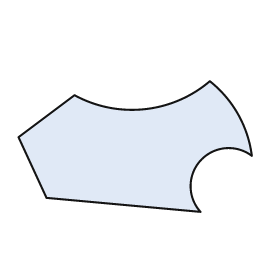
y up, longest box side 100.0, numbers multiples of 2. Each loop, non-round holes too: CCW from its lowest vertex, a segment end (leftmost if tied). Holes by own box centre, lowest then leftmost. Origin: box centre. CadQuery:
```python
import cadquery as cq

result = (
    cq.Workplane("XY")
    .moveTo(28.0, -28.0)
    .threePointArc((28.0, -6.0), (50.0, -4.0))
    .threePointArc((44.0, 14.0), (32.0, 28.0))
    .threePointArc((4.0, 16.0), (-26.0, 22.0))
    .lineTo(-50.0, 4.0)
    .lineTo(-38.0, -22.0)
    .close()
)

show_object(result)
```